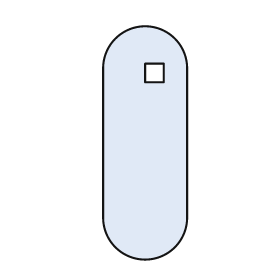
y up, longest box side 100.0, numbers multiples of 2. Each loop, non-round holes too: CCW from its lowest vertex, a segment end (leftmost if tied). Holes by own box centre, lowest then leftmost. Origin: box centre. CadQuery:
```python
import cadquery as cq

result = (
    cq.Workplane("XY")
    .moveTo(-18.0, -32.0)
    .threePointArc((0.0, -50.0), (18.0, -32.0))
    .lineTo(18.0, 32.0)
    .threePointArc((0.0, 50.0), (-18.0, 32.0))
    .close()
    .moveTo(0.0, 26.0)
    .lineTo(8.0, 26.0)
    .lineTo(8.0, 34.0)
    .lineTo(0.0, 34.0)
    .close()
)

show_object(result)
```